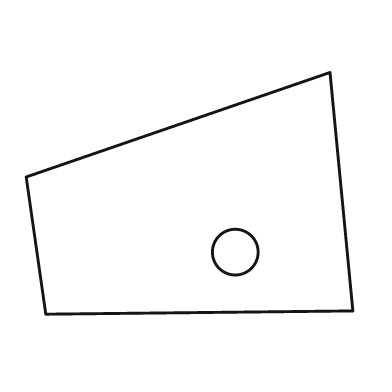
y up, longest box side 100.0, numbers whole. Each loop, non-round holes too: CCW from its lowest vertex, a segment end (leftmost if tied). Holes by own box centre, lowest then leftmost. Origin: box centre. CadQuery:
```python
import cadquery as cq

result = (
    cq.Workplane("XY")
    .moveTo(-44.0, -37.0)
    .lineTo(50.0, -36.0)
    .lineTo(43.0, 37.0)
    .lineTo(-50.0, 5.0)
    .close()
    .moveTo(14.0, -18.0)
    .circle(7.0)
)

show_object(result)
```